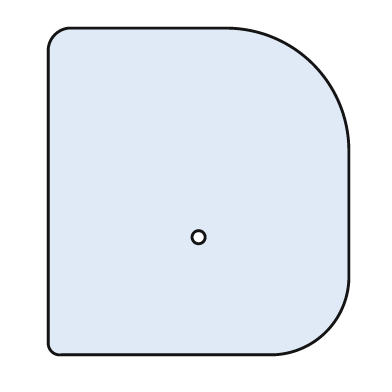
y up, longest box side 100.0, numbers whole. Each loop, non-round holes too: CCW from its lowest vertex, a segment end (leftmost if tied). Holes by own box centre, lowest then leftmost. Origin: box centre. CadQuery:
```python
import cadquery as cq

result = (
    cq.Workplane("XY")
    .moveTo(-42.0, -50.0)
    .lineTo(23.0, -50.0)
    .threePointArc((39.0, -43.0), (46.0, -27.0))
    .lineTo(46.0, 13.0)
    .threePointArc((35.0, 39.0), (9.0, 50.0))
    .lineTo(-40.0, 50.0)
    .threePointArc((-44.0, 48.0), (-46.0, 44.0))
    .lineTo(-46.0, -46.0)
    .threePointArc((-45.0, -49.0), (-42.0, -50.0))
    .close()
    .moveTo(0.0, -14.0)
    .circle(2.0)
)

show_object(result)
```